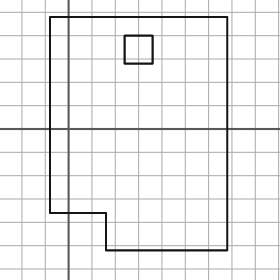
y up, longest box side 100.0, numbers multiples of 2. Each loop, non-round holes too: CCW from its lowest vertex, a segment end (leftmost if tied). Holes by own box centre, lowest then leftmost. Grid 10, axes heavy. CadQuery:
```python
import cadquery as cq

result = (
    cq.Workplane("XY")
    .moveTo(16.0, -52.0)
    .lineTo(68.0, -52.0)
    .lineTo(68.0, 48.0)
    .lineTo(-8.0, 48.0)
    .lineTo(-8.0, -36.0)
    .lineTo(16.0, -36.0)
    .close()
    .moveTo(24.0, 28.0)
    .lineTo(36.0, 28.0)
    .lineTo(36.0, 40.0)
    .lineTo(24.0, 40.0)
    .close()
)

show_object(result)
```